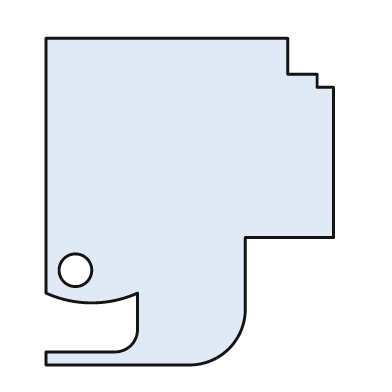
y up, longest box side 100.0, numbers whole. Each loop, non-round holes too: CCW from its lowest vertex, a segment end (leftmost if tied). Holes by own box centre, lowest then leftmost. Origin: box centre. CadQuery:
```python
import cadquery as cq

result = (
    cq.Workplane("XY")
    .moveTo(-44.0, -50.0)
    .lineTo(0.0, -50.0)
    .threePointArc((12.0, -45.0), (17.0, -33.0))
    .lineTo(17.0, -11.0)
    .lineTo(44.0, -11.0)
    .lineTo(44.0, 35.0)
    .lineTo(39.0, 35.0)
    .lineTo(39.0, 39.0)
    .lineTo(30.0, 39.0)
    .lineTo(30.0, 50.0)
    .lineTo(-44.0, 50.0)
    .lineTo(-44.0, -28.0)
    .threePointArc((-30.0, -31.0), (-16.0, -28.0))
    .lineTo(-16.0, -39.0)
    .threePointArc((-18.0, -44.0), (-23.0, -46.0))
    .lineTo(-44.0, -46.0)
    .close()
    .moveTo(-35.0, -21.0)
    .circle(5.0)
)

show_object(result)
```